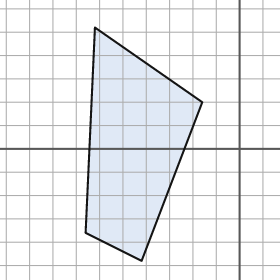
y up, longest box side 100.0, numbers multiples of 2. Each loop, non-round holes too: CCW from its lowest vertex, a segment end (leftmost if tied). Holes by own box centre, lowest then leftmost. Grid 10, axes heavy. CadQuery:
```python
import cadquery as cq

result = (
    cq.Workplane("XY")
    .moveTo(-42.0, -48.0)
    .lineTo(-16.0, 20.0)
    .lineTo(-62.0, 52.0)
    .lineTo(-66.0, -36.0)
    .close()
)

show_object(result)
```